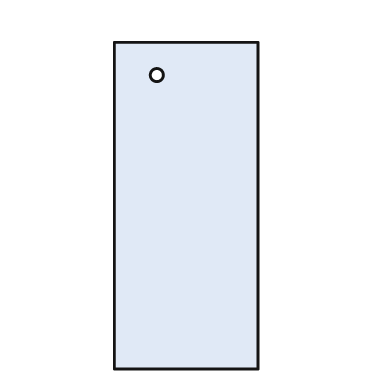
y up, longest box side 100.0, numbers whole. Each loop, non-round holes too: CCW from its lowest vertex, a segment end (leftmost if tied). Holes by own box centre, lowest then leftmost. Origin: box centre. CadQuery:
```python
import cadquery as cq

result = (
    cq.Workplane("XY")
    .moveTo(-22.0, -50.0)
    .lineTo(22.0, -50.0)
    .lineTo(22.0, 50.0)
    .lineTo(-22.0, 50.0)
    .close()
    .moveTo(-9.0, 40.0)
    .circle(2.0)
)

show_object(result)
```